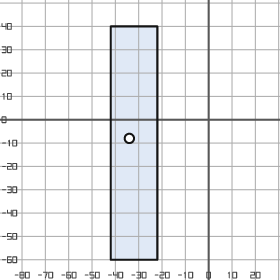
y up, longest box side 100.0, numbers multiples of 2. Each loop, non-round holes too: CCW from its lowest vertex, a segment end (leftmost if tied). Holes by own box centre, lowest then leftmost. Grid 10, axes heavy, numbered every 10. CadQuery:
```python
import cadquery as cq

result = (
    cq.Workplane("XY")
    .moveTo(-42.0, -60.0)
    .lineTo(-22.0, -60.0)
    .lineTo(-22.0, 40.0)
    .lineTo(-42.0, 40.0)
    .close()
    .moveTo(-34.0, -8.0)
    .circle(2.0)
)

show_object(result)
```